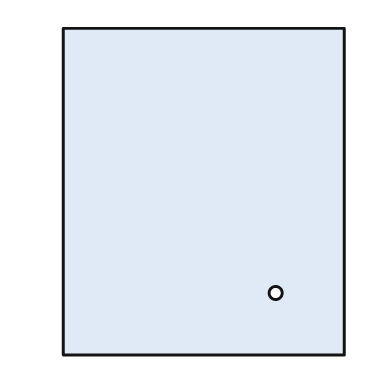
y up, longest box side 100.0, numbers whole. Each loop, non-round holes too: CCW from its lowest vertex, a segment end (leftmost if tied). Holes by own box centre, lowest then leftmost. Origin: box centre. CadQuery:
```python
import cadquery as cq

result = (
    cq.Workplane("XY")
    .moveTo(-43.0, -50.0)
    .lineTo(43.0, -50.0)
    .lineTo(43.0, 50.0)
    .lineTo(-43.0, 50.0)
    .close()
    .moveTo(22.0, -31.0)
    .circle(2.0)
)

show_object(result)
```